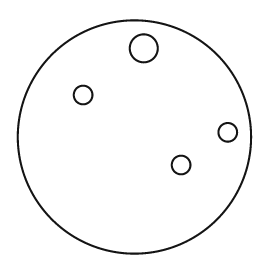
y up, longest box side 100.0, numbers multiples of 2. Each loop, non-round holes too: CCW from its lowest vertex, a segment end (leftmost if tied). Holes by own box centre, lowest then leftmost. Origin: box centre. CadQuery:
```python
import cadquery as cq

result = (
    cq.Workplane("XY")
    .moveTo(0.0, 0.0)
    .circle(50.0)
    .moveTo(20.0, -12.0)
    .circle(4.0)
    .moveTo(40.0, 2.0)
    .circle(4.0)
    .moveTo(-22.0, 18.0)
    .circle(4.0)
    .moveTo(4.0, 38.0)
    .circle(6.0)
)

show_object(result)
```